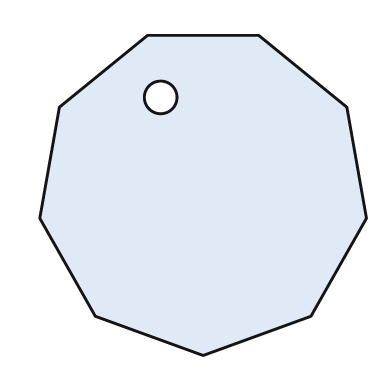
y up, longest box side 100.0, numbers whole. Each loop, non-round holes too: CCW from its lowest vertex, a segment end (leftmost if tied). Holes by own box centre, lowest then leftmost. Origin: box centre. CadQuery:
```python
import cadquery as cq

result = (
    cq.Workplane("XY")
    .moveTo(0.0, -49.0)
    .lineTo(33.0, -37.0)
    .lineTo(50.0, -7.0)
    .lineTo(44.0, 27.0)
    .lineTo(17.0, 49.0)
    .lineTo(-17.0, 49.0)
    .lineTo(-44.0, 27.0)
    .lineTo(-50.0, -7.0)
    .lineTo(-33.0, -37.0)
    .close()
    .moveTo(-13.0, 30.0)
    .circle(5.0)
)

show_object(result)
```